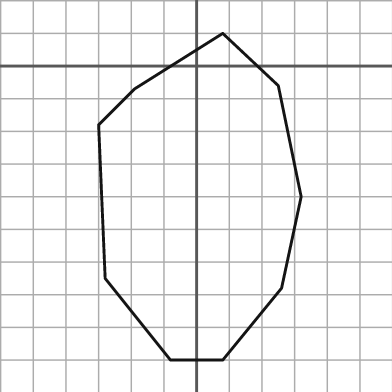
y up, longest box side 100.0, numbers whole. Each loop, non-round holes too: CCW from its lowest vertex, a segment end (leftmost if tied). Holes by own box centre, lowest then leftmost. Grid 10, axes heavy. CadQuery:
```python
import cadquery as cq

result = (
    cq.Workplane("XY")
    .moveTo(-8.0, -90.0)
    .lineTo(8.0, -90.0)
    .lineTo(26.0, -68.0)
    .lineTo(32.0, -40.0)
    .lineTo(25.0, -6.0)
    .lineTo(8.0, 10.0)
    .lineTo(-19.0, -7.0)
    .lineTo(-30.0, -18.0)
    .lineTo(-28.0, -65.0)
    .close()
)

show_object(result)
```